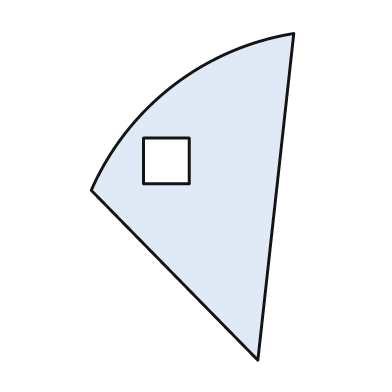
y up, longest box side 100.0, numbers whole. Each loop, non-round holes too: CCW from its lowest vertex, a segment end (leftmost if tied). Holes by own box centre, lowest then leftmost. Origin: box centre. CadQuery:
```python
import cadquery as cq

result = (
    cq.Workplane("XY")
    .moveTo(20.0, -50.0)
    .lineTo(31.0, 50.0)
    .threePointArc((-6.0, 34.0), (-31.0, 2.0))
    .close()
    .moveTo(-15.0, 4.0)
    .lineTo(-1.0, 4.0)
    .lineTo(-1.0, 18.0)
    .lineTo(-15.0, 18.0)
    .close()
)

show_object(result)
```